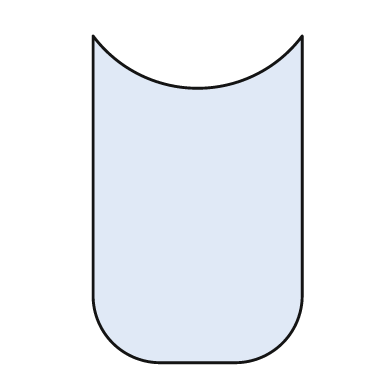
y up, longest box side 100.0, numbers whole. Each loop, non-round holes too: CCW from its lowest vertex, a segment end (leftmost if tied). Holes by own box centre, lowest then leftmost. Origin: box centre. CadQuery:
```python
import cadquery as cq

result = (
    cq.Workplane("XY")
    .moveTo(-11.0, -50.0)
    .lineTo(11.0, -50.0)
    .threePointArc((26.0, -44.0), (32.0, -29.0))
    .lineTo(32.0, 50.0)
    .threePointArc((0.0, 34.0), (-32.0, 50.0))
    .lineTo(-32.0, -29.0)
    .threePointArc((-26.0, -44.0), (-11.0, -50.0))
    .close()
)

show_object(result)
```